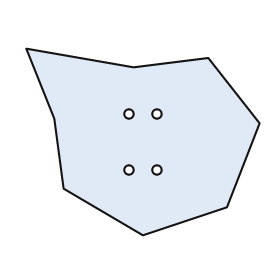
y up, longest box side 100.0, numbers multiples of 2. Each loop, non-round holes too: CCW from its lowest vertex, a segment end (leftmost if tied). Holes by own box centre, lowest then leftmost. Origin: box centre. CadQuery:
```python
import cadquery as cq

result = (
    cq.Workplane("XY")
    .moveTo(0.0, -40.0)
    .lineTo(36.0, -28.0)
    .lineTo(50.0, 8.0)
    .lineTo(28.0, 36.0)
    .lineTo(-4.0, 32.0)
    .lineTo(-50.0, 40.0)
    .lineTo(-38.0, 10.0)
    .lineTo(-34.0, -20.0)
    .close()
    .moveTo(-6.0, -12.0)
    .circle(2.0)
    .moveTo(6.0, -12.0)
    .circle(2.0)
    .moveTo(-6.0, 12.0)
    .circle(2.0)
    .moveTo(6.0, 12.0)
    .circle(2.0)
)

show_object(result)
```